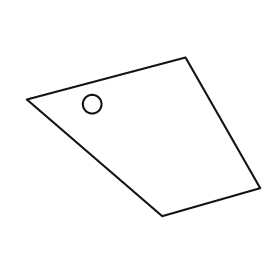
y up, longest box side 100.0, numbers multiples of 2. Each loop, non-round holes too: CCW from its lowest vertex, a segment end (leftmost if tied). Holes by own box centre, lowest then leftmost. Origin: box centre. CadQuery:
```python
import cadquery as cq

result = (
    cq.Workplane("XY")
    .moveTo(8.0, -34.0)
    .lineTo(50.0, -22.0)
    .lineTo(18.0, 34.0)
    .lineTo(-50.0, 16.0)
    .close()
    .moveTo(-22.0, 14.0)
    .circle(4.0)
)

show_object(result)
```